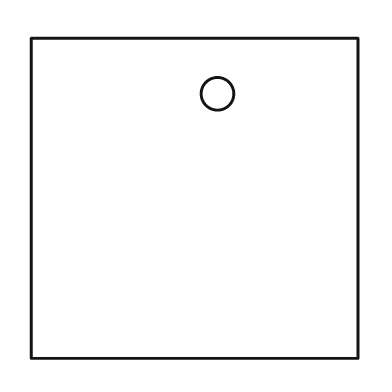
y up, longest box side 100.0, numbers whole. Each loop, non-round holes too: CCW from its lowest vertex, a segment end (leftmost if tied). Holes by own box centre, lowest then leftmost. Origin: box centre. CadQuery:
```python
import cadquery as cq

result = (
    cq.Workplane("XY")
    .moveTo(-50.0, -49.0)
    .lineTo(50.0, -49.0)
    .lineTo(50.0, 49.0)
    .lineTo(-50.0, 49.0)
    .close()
    .moveTo(7.0, 32.0)
    .circle(5.0)
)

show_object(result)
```